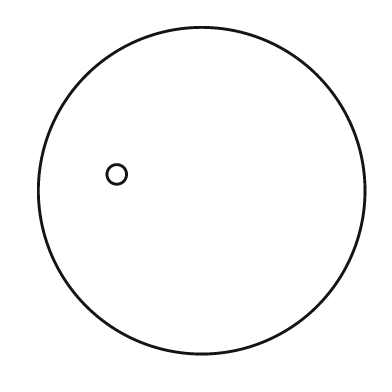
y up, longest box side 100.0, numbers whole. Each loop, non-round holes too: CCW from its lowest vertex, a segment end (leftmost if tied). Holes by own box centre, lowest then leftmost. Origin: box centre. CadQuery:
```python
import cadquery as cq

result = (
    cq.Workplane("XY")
    .moveTo(0.0, 0.0)
    .circle(50.0)
    .moveTo(-26.0, 5.0)
    .circle(3.0)
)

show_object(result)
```